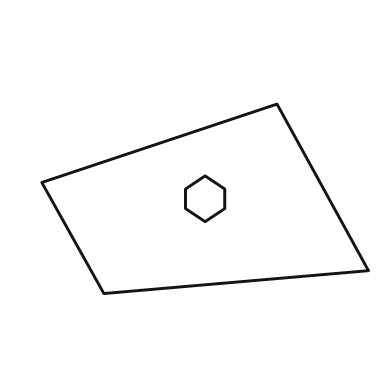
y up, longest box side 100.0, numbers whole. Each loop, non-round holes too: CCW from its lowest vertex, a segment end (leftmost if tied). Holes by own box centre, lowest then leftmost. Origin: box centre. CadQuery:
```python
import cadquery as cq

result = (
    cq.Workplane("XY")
    .moveTo(-31.0, -29.0)
    .lineTo(50.0, -22.0)
    .lineTo(22.0, 29.0)
    .lineTo(-50.0, 5.0)
    .close()
    .moveTo(0.0, -7.0)
    .lineTo(6.0, -3.0)
    .lineTo(6.0, 3.0)
    .lineTo(0.0, 7.0)
    .lineTo(-6.0, 3.0)
    .lineTo(-6.0, -3.0)
    .close()
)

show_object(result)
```